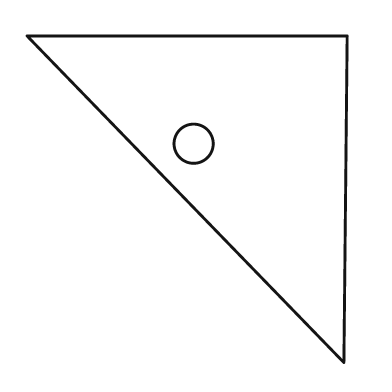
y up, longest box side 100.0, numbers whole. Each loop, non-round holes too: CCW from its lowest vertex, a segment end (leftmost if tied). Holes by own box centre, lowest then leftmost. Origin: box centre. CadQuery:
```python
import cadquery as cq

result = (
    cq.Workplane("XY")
    .moveTo(48.0, -50.0)
    .lineTo(49.0, 50.0)
    .lineTo(-49.0, 50.0)
    .close()
    .moveTo(2.0, 17.0)
    .circle(6.0)
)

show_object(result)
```